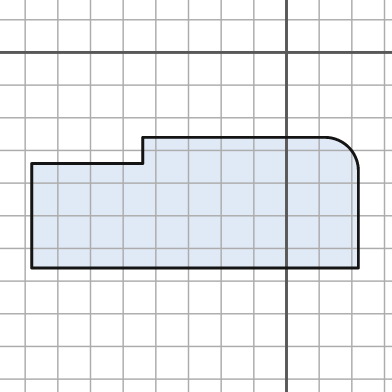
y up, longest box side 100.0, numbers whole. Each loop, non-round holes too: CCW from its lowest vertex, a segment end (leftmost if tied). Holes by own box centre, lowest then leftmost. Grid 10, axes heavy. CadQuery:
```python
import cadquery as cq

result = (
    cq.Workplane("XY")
    .moveTo(-78.0, -66.0)
    .lineTo(22.0, -66.0)
    .lineTo(22.0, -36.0)
    .threePointArc((19.0, -29.0), (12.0, -26.0))
    .lineTo(-44.0, -26.0)
    .lineTo(-44.0, -34.0)
    .lineTo(-78.0, -34.0)
    .close()
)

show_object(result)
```